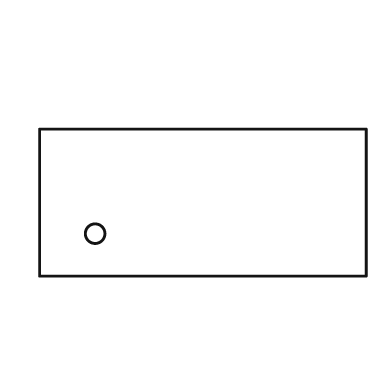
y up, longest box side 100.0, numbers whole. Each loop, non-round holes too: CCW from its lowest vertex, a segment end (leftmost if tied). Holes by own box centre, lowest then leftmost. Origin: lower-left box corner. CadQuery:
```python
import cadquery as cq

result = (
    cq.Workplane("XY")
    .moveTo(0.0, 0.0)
    .lineTo(100.0, 0.0)
    .lineTo(100.0, 45.0)
    .lineTo(0.0, 45.0)
    .close()
    .moveTo(17.0, 13.0)
    .circle(3.0)
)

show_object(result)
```